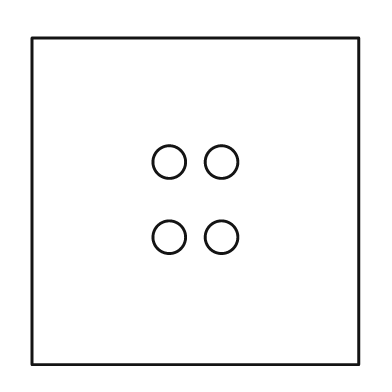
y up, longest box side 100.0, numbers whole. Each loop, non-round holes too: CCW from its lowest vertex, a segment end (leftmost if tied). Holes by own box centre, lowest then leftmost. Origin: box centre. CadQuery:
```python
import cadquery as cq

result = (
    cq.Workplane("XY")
    .moveTo(-50.0, -50.0)
    .lineTo(50.0, -50.0)
    .lineTo(50.0, 50.0)
    .lineTo(-50.0, 50.0)
    .close()
    .moveTo(-8.0, -11.0)
    .circle(5.0)
    .moveTo(8.0, -11.0)
    .circle(5.0)
    .moveTo(-8.0, 12.0)
    .circle(5.0)
    .moveTo(8.0, 12.0)
    .circle(5.0)
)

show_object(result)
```